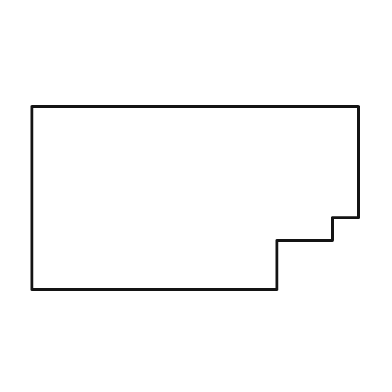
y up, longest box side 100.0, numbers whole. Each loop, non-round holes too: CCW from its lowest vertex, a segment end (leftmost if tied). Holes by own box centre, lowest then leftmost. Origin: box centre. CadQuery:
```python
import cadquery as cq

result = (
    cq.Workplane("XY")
    .moveTo(-50.0, -28.0)
    .lineTo(25.0, -28.0)
    .lineTo(25.0, -13.0)
    .lineTo(42.0, -13.0)
    .lineTo(42.0, -6.0)
    .lineTo(50.0, -6.0)
    .lineTo(50.0, 28.0)
    .lineTo(-50.0, 28.0)
    .close()
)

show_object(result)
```